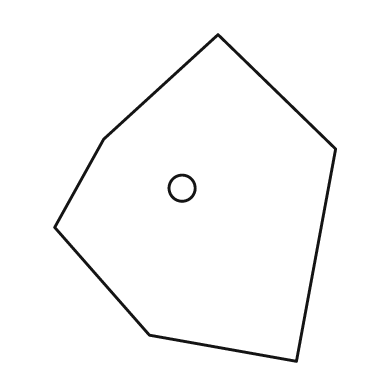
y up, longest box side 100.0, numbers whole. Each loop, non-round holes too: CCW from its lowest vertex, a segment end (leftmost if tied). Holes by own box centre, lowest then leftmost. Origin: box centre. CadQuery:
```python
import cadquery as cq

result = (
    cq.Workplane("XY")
    .moveTo(31.0, -50.0)
    .lineTo(43.0, 15.0)
    .lineTo(7.0, 50.0)
    .lineTo(-28.0, 18.0)
    .lineTo(-43.0, -9.0)
    .lineTo(-14.0, -42.0)
    .close()
    .moveTo(-4.0, 3.0)
    .circle(4.0)
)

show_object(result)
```